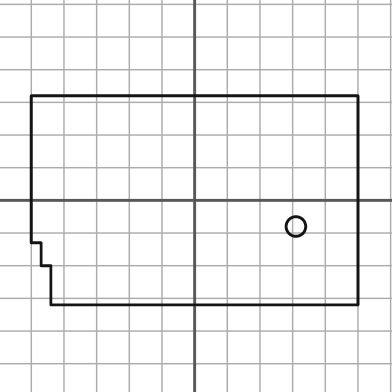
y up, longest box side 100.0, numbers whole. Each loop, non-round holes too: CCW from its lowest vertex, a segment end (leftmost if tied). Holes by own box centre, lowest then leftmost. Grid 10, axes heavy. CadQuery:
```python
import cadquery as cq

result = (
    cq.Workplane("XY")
    .moveTo(-44.0, -32.0)
    .lineTo(50.0, -32.0)
    .lineTo(50.0, 32.0)
    .lineTo(-50.0, 32.0)
    .lineTo(-50.0, -13.0)
    .lineTo(-47.0, -13.0)
    .lineTo(-47.0, -20.0)
    .lineTo(-44.0, -20.0)
    .close()
    .moveTo(31.0, -8.0)
    .circle(3.0)
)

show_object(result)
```